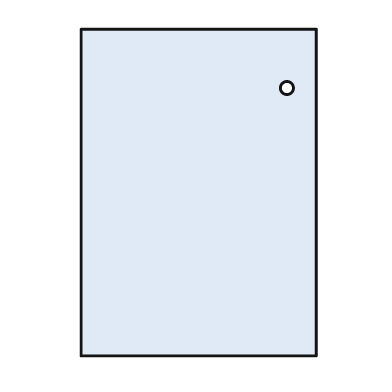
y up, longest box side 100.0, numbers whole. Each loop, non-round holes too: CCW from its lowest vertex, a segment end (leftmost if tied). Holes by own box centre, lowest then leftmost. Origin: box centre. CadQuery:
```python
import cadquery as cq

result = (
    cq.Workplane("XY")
    .moveTo(-36.0, -50.0)
    .lineTo(36.0, -50.0)
    .lineTo(36.0, 50.0)
    .lineTo(-36.0, 50.0)
    .close()
    .moveTo(27.0, 32.0)
    .circle(2.0)
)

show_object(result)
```